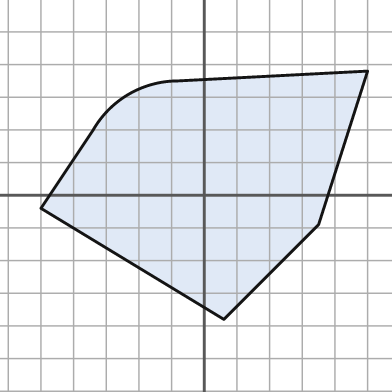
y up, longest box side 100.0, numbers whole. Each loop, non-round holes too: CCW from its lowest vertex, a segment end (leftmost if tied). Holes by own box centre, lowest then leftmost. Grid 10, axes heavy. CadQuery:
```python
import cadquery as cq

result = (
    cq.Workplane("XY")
    .moveTo(6.0, -38.0)
    .lineTo(35.0, -9.0)
    .lineTo(50.0, 38.0)
    .lineTo(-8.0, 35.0)
    .threePointArc((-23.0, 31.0), (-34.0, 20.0))
    .lineTo(-50.0, -4.0)
    .close()
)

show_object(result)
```